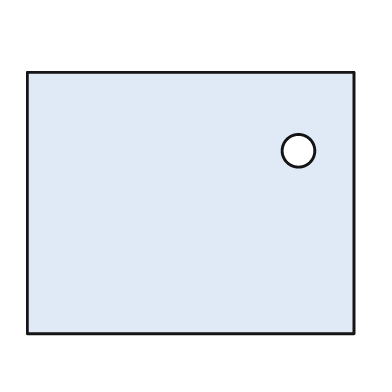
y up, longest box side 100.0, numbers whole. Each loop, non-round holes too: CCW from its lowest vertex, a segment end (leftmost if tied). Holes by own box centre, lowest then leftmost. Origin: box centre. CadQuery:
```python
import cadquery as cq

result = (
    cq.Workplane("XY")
    .moveTo(-50.0, -40.0)
    .lineTo(50.0, -40.0)
    .lineTo(50.0, 40.0)
    .lineTo(-50.0, 40.0)
    .close()
    .moveTo(33.0, 16.0)
    .circle(5.0)
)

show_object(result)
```